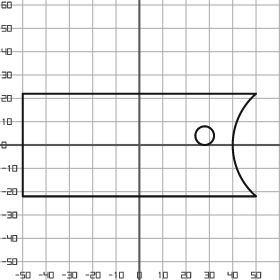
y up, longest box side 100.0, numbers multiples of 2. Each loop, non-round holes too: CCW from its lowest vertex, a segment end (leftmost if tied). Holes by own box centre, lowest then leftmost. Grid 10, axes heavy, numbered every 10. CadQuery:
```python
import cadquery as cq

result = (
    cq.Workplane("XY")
    .moveTo(-50.0, -22.0)
    .lineTo(50.0, -22.0)
    .threePointArc((40.0, 0.0), (50.0, 22.0))
    .lineTo(-50.0, 22.0)
    .close()
    .moveTo(28.0, 4.0)
    .circle(4.0)
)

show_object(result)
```